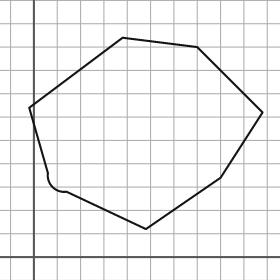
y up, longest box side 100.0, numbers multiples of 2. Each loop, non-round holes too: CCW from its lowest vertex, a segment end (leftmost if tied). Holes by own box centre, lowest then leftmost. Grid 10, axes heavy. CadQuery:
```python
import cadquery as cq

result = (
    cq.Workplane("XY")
    .moveTo(48.0, 12.0)
    .lineTo(80.0, 34.0)
    .lineTo(98.0, 62.0)
    .lineTo(70.0, 90.0)
    .lineTo(38.0, 94.0)
    .lineTo(-2.0, 64.0)
    .lineTo(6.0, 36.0)
    .threePointArc((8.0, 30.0), (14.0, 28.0))
    .close()
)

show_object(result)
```